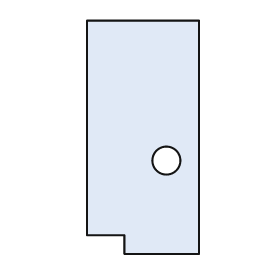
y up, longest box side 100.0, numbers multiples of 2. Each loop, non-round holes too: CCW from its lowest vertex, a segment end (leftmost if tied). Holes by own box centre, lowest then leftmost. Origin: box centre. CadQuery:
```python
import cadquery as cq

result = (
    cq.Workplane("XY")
    .moveTo(-8.0, -50.0)
    .lineTo(24.0, -50.0)
    .lineTo(24.0, 50.0)
    .lineTo(-24.0, 50.0)
    .lineTo(-24.0, -42.0)
    .lineTo(-8.0, -42.0)
    .close()
    .moveTo(10.0, -10.0)
    .circle(6.0)
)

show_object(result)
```